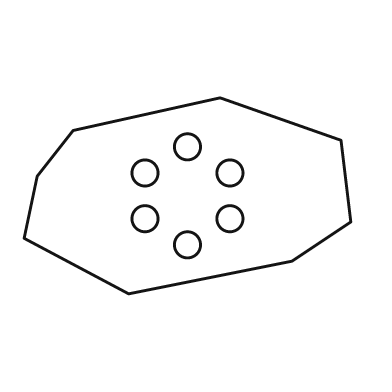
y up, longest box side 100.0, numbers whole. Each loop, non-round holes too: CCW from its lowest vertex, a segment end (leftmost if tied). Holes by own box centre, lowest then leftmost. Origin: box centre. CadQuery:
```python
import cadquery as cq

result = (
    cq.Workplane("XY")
    .moveTo(-18.0, -30.0)
    .lineTo(32.0, -20.0)
    .lineTo(50.0, -8.0)
    .lineTo(47.0, 17.0)
    .lineTo(10.0, 30.0)
    .lineTo(-35.0, 20.0)
    .lineTo(-46.0, 6.0)
    .lineTo(-50.0, -13.0)
    .close()
    .moveTo(0.0, -15.0)
    .circle(4.0)
    .moveTo(-13.0, -7.0)
    .circle(4.0)
    .moveTo(13.0, -7.0)
    .circle(4.0)
    .moveTo(-13.0, 7.0)
    .circle(4.0)
    .moveTo(13.0, 7.0)
    .circle(4.0)
    .moveTo(0.0, 15.0)
    .circle(4.0)
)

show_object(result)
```